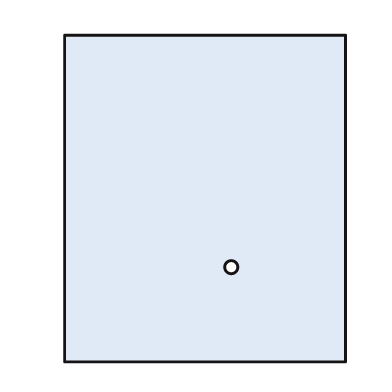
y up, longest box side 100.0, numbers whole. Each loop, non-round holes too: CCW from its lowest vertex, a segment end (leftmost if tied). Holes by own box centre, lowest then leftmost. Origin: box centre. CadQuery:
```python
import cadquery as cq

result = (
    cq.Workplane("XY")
    .moveTo(-43.0, -50.0)
    .lineTo(43.0, -50.0)
    .lineTo(43.0, 50.0)
    .lineTo(-43.0, 50.0)
    .close()
    .moveTo(8.0, -21.0)
    .circle(2.0)
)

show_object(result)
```